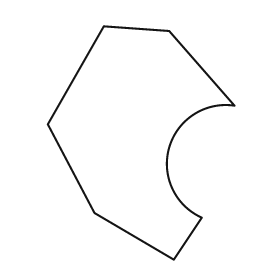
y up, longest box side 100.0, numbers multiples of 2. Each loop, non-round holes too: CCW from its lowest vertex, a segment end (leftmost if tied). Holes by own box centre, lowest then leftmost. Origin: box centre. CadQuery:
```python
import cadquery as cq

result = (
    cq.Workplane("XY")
    .moveTo(14.0, -50.0)
    .lineTo(26.0, -32.0)
    .threePointArc((12.0, -2.0), (40.0, 16.0))
    .lineTo(12.0, 48.0)
    .lineTo(-16.0, 50.0)
    .lineTo(-40.0, 8.0)
    .lineTo(-20.0, -30.0)
    .close()
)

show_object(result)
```